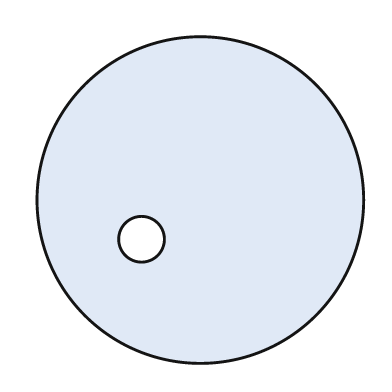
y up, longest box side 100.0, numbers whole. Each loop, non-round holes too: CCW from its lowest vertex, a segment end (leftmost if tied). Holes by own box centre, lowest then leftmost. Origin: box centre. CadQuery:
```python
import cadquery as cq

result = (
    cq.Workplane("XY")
    .moveTo(0.0, 0.0)
    .circle(50.0)
    .moveTo(-18.0, -12.0)
    .circle(7.0)
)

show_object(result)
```